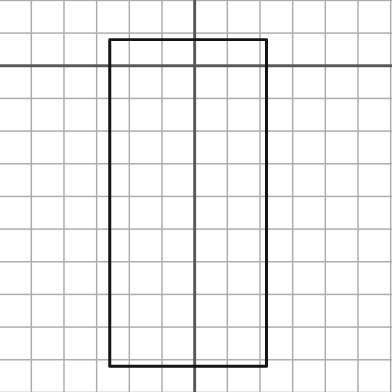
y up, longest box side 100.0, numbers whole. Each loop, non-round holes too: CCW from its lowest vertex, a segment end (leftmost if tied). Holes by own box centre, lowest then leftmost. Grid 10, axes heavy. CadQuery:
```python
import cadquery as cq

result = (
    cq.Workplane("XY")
    .moveTo(-26.0, -92.0)
    .lineTo(22.0, -92.0)
    .lineTo(22.0, 8.0)
    .lineTo(-26.0, 8.0)
    .close()
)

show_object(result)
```